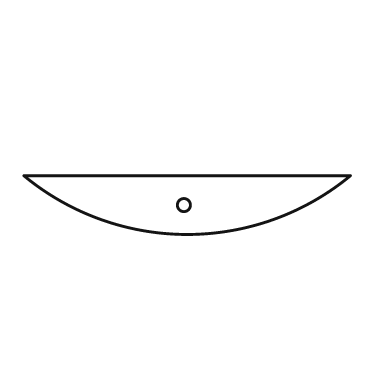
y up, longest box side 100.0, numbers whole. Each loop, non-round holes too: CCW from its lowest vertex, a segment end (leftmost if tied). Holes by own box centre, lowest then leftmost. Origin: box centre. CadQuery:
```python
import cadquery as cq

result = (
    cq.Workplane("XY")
    .moveTo(-50.0, 9.0)
    .threePointArc((0.0, -9.0), (50.0, 9.0))
    .close()
    .moveTo(-1.0, 0.0)
    .circle(2.0)
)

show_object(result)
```